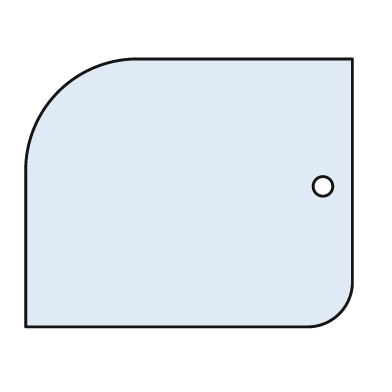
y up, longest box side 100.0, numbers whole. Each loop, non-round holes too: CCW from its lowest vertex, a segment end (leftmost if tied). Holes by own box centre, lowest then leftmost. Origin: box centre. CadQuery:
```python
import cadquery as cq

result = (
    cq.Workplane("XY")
    .moveTo(-50.0, -41.0)
    .lineTo(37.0, -41.0)
    .threePointArc((46.0, -37.0), (50.0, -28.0))
    .lineTo(50.0, 41.0)
    .lineTo(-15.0, 41.0)
    .threePointArc((-40.0, 31.0), (-50.0, 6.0))
    .close()
    .moveTo(41.0, 2.0)
    .circle(3.0)
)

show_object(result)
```